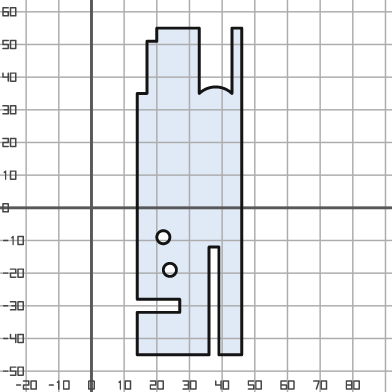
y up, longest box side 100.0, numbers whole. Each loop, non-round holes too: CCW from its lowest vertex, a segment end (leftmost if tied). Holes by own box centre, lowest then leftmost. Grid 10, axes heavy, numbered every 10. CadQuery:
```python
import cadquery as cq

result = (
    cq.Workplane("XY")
    .moveTo(14.0, -45.0)
    .lineTo(36.0, -45.0)
    .lineTo(36.0, -12.0)
    .lineTo(39.0, -12.0)
    .lineTo(39.0, -45.0)
    .lineTo(46.0, -45.0)
    .lineTo(46.0, 55.0)
    .lineTo(43.0, 55.0)
    .lineTo(43.0, 35.0)
    .threePointArc((38.0, 37.0), (33.0, 35.0))
    .lineTo(33.0, 55.0)
    .lineTo(20.0, 55.0)
    .lineTo(20.0, 51.0)
    .lineTo(17.0, 51.0)
    .lineTo(17.0, 35.0)
    .lineTo(14.0, 35.0)
    .lineTo(14.0, -28.0)
    .lineTo(27.0, -28.0)
    .lineTo(27.0, -32.0)
    .lineTo(14.0, -32.0)
    .close()
    .moveTo(24.0, -19.0)
    .circle(2.0)
    .moveTo(22.0, -9.0)
    .circle(2.0)
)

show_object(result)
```